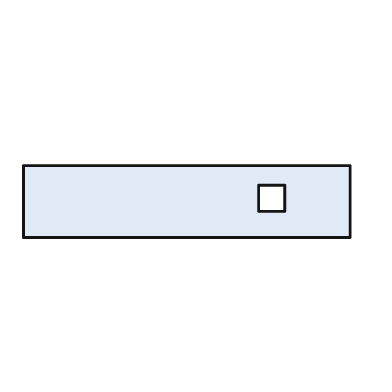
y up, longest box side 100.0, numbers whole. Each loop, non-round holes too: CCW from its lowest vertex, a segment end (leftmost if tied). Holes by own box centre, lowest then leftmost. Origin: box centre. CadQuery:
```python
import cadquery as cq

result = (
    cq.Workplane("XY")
    .moveTo(-50.0, -11.0)
    .lineTo(50.0, -11.0)
    .lineTo(50.0, 11.0)
    .lineTo(-50.0, 11.0)
    .close()
    .moveTo(22.0, -3.0)
    .lineTo(30.0, -3.0)
    .lineTo(30.0, 5.0)
    .lineTo(22.0, 5.0)
    .close()
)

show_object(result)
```